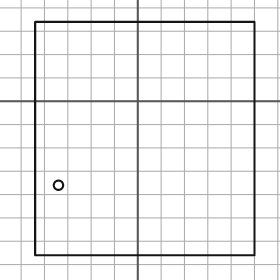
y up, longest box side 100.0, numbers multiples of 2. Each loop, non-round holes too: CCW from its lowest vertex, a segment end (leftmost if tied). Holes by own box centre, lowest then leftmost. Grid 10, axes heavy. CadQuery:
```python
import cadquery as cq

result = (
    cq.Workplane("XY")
    .moveTo(-44.0, -66.0)
    .lineTo(50.0, -66.0)
    .lineTo(50.0, 34.0)
    .lineTo(-44.0, 34.0)
    .close()
    .moveTo(-34.0, -36.0)
    .circle(2.0)
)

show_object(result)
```